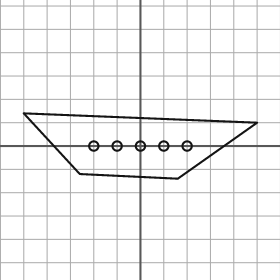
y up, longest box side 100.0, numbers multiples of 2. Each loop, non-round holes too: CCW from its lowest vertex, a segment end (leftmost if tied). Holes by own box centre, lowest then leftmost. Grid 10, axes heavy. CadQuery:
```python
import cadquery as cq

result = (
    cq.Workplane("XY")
    .moveTo(16.0, -14.0)
    .lineTo(50.0, 10.0)
    .lineTo(-50.0, 14.0)
    .lineTo(-26.0, -12.0)
    .close()
    .moveTo(-20.0, 0.0)
    .circle(2.0)
    .moveTo(-10.0, 0.0)
    .circle(2.0)
    .moveTo(0.0, 0.0)
    .circle(2.0)
    .moveTo(10.0, 0.0)
    .circle(2.0)
    .moveTo(20.0, 0.0)
    .circle(2.0)
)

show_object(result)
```